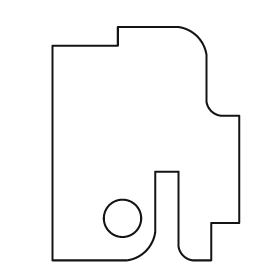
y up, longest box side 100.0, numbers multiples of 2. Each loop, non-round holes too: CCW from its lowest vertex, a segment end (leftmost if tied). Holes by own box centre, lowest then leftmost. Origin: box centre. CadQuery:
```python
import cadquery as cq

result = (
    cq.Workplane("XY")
    .moveTo(-40.0, -50.0)
    .lineTo(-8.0, -50.0)
    .threePointArc((0.0, -46.0), (4.0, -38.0))
    .lineTo(4.0, -12.0)
    .lineTo(14.0, -12.0)
    .lineTo(14.0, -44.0)
    .threePointArc((16.0, -48.0), (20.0, -50.0))
    .lineTo(28.0, -50.0)
    .lineTo(28.0, -34.0)
    .lineTo(40.0, -34.0)
    .lineTo(40.0, 12.0)
    .lineTo(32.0, 12.0)
    .threePointArc((28.0, 14.0), (26.0, 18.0))
    .lineTo(26.0, 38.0)
    .threePointArc((22.0, 46.0), (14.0, 50.0))
    .lineTo(-12.0, 50.0)
    .lineTo(-12.0, 42.0)
    .lineTo(-40.0, 42.0)
    .close()
    .moveTo(-10.0, -32.0)
    .circle(8.0)
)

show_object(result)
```